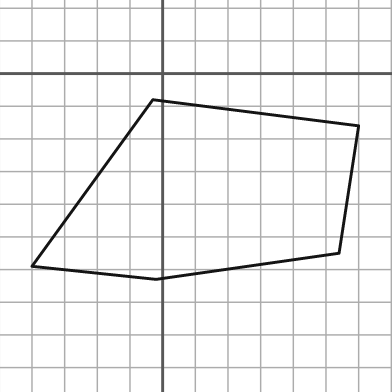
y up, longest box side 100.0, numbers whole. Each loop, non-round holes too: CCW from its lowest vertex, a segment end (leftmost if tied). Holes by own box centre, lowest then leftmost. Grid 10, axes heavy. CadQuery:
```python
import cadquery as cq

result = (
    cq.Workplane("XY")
    .moveTo(-2.0, -63.0)
    .lineTo(54.0, -55.0)
    .lineTo(60.0, -16.0)
    .lineTo(-3.0, -8.0)
    .lineTo(-40.0, -59.0)
    .close()
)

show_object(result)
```